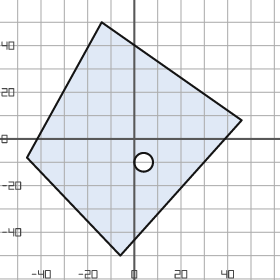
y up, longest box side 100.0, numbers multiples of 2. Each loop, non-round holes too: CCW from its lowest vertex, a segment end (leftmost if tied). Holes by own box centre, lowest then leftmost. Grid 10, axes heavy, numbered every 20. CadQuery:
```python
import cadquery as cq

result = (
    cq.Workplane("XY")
    .moveTo(-6.0, -50.0)
    .lineTo(46.0, 8.0)
    .lineTo(-14.0, 50.0)
    .lineTo(-46.0, -8.0)
    .close()
    .moveTo(4.0, -10.0)
    .circle(4.0)
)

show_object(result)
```